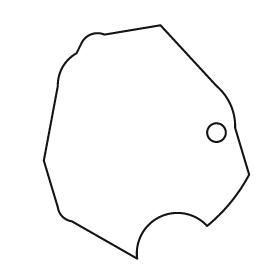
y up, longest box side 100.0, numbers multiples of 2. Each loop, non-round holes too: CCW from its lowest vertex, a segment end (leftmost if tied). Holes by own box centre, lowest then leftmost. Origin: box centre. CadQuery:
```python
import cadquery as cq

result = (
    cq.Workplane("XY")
    .moveTo(-4.0, -50.0)
    .threePointArc((6.0, -32.0), (26.0, -36.0))
    .threePointArc((36.0, -26.0), (44.0, -14.0))
    .lineTo(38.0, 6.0)
    .threePointArc((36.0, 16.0), (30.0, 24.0))
    .lineTo(6.0, 50.0)
    .lineTo(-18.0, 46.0)
    .threePointArc((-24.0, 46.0), (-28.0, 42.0))
    .lineTo(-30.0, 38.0)
    .threePointArc((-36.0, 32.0), (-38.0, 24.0))
    .lineTo(-44.0, -8.0)
    .lineTo(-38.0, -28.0)
    .threePointArc((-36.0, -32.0), (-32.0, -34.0))
    .close()
    .moveTo(30.0, 4.0)
    .circle(4.0)
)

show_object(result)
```